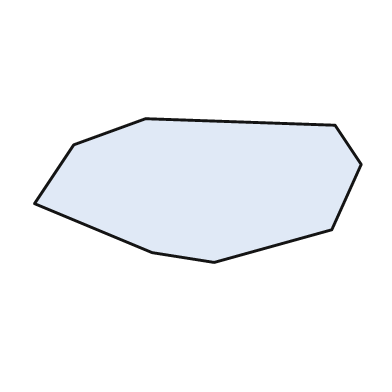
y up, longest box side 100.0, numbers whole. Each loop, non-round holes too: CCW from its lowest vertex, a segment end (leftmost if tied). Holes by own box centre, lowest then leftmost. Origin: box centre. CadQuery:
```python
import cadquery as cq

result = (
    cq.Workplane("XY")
    .moveTo(5.0, -22.0)
    .lineTo(41.0, -12.0)
    .lineTo(50.0, 8.0)
    .lineTo(42.0, 20.0)
    .lineTo(-16.0, 22.0)
    .lineTo(-38.0, 14.0)
    .lineTo(-50.0, -4.0)
    .lineTo(-14.0, -19.0)
    .close()
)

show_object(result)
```